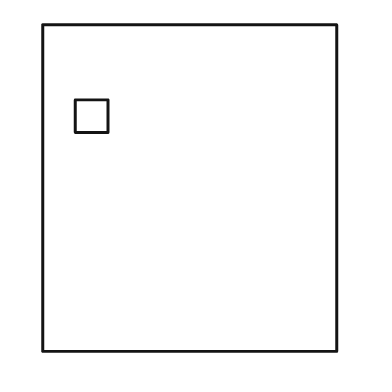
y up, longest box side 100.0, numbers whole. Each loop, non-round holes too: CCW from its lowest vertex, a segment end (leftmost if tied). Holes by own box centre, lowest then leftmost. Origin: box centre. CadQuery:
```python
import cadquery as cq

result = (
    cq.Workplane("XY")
    .moveTo(-45.0, -50.0)
    .lineTo(45.0, -50.0)
    .lineTo(45.0, 50.0)
    .lineTo(-45.0, 50.0)
    .close()
    .moveTo(-35.0, 17.0)
    .lineTo(-25.0, 17.0)
    .lineTo(-25.0, 27.0)
    .lineTo(-35.0, 27.0)
    .close()
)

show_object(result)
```